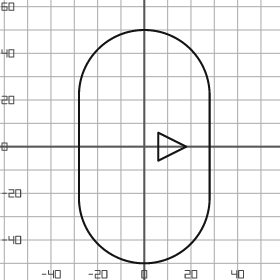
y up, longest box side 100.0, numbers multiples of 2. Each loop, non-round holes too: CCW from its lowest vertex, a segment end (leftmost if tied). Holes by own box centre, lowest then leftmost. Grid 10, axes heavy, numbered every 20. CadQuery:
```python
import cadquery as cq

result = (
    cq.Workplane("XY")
    .moveTo(-28.0, -22.0)
    .threePointArc((0.0, -50.0), (28.0, -22.0))
    .lineTo(28.0, 22.0)
    .threePointArc((0.0, 50.0), (-28.0, 22.0))
    .close()
    .moveTo(6.0, -6.0)
    .lineTo(18.0, 0.0)
    .lineTo(6.0, 6.0)
    .close()
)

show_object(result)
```